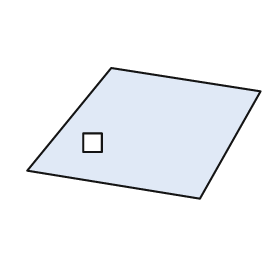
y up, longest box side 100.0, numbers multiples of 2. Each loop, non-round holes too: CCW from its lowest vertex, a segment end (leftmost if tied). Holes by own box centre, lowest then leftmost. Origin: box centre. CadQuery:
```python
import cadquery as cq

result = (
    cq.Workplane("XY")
    .moveTo(24.0, -28.0)
    .lineTo(50.0, 18.0)
    .lineTo(-14.0, 28.0)
    .lineTo(-50.0, -16.0)
    .close()
    .moveTo(-26.0, -8.0)
    .lineTo(-18.0, -8.0)
    .lineTo(-18.0, 0.0)
    .lineTo(-26.0, 0.0)
    .close()
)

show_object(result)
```